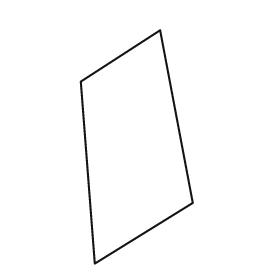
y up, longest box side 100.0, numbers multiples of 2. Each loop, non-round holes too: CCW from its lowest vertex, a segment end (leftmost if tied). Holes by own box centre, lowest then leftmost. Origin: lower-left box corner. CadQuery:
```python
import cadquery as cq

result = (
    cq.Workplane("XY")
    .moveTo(6.0, 0.0)
    .lineTo(48.0, 26.0)
    .lineTo(34.0, 100.0)
    .lineTo(0.0, 78.0)
    .close()
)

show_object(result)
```